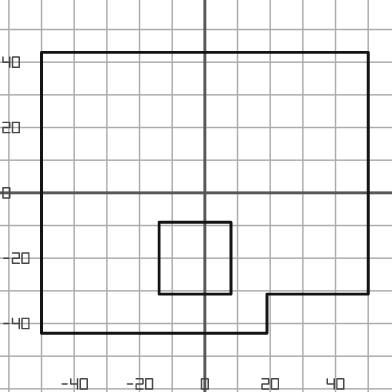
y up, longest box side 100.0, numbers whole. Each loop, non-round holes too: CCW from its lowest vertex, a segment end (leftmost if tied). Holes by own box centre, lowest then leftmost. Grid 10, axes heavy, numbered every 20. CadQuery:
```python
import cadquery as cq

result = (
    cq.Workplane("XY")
    .moveTo(-50.0, -43.0)
    .lineTo(19.0, -43.0)
    .lineTo(19.0, -31.0)
    .lineTo(50.0, -31.0)
    .lineTo(50.0, 43.0)
    .lineTo(-50.0, 43.0)
    .close()
    .moveTo(-14.0, -31.0)
    .lineTo(8.0, -31.0)
    .lineTo(8.0, -9.0)
    .lineTo(-14.0, -9.0)
    .close()
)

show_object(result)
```